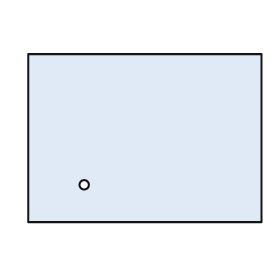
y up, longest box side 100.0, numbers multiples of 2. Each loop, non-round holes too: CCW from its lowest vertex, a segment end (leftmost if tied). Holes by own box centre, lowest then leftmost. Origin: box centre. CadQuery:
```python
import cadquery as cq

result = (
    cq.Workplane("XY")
    .moveTo(-50.0, -36.0)
    .lineTo(50.0, -36.0)
    .lineTo(50.0, 36.0)
    .lineTo(-50.0, 36.0)
    .close()
    .moveTo(-26.0, -20.0)
    .circle(2.0)
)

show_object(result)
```